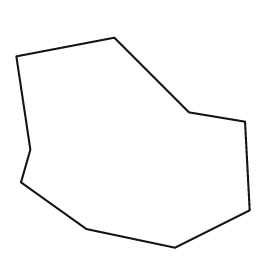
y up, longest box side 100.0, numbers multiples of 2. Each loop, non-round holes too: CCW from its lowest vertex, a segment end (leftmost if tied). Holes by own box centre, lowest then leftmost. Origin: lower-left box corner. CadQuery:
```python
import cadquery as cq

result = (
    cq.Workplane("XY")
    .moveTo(68.0, 0.0)
    .lineTo(100.0, 16.0)
    .lineTo(98.0, 54.0)
    .lineTo(74.0, 58.0)
    .lineTo(42.0, 90.0)
    .lineTo(0.0, 82.0)
    .lineTo(6.0, 42.0)
    .lineTo(2.0, 28.0)
    .lineTo(30.0, 8.0)
    .close()
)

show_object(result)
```